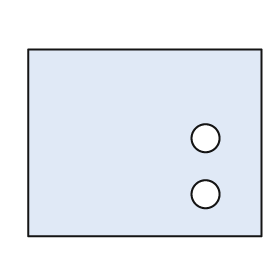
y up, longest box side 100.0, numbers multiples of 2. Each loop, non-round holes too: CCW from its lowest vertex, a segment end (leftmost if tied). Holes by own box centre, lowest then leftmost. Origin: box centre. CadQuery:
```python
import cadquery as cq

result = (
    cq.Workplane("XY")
    .moveTo(-50.0, -40.0)
    .lineTo(50.0, -40.0)
    .lineTo(50.0, 40.0)
    .lineTo(-50.0, 40.0)
    .close()
    .moveTo(26.0, -22.0)
    .circle(6.0)
    .moveTo(26.0, 2.0)
    .circle(6.0)
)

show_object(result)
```